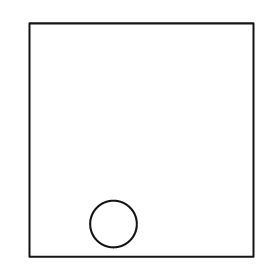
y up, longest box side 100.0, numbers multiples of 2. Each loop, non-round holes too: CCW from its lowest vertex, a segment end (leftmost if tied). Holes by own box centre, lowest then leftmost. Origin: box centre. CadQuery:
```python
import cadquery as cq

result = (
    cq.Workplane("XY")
    .moveTo(-48.0, -50.0)
    .lineTo(48.0, -50.0)
    .lineTo(48.0, 50.0)
    .lineTo(-48.0, 50.0)
    .close()
    .moveTo(-12.0, -36.0)
    .circle(10.0)
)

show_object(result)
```